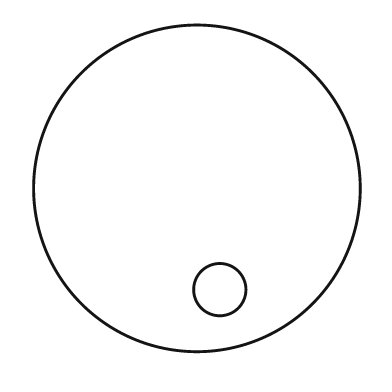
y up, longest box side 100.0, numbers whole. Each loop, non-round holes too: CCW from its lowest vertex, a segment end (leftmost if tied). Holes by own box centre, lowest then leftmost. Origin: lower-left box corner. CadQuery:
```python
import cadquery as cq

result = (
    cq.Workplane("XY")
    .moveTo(50.0, 50.0)
    .circle(50.0)
    .moveTo(57.0, 19.0)
    .circle(8.0)
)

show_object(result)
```